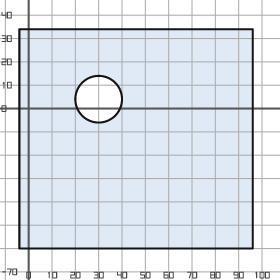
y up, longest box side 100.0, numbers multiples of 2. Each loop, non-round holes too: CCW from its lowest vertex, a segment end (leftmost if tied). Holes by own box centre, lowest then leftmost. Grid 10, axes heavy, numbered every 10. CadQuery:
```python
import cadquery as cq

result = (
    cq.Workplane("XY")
    .moveTo(-4.0, -60.0)
    .lineTo(96.0, -60.0)
    .lineTo(96.0, 34.0)
    .lineTo(-4.0, 34.0)
    .close()
    .moveTo(30.0, 4.0)
    .circle(10.0)
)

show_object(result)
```